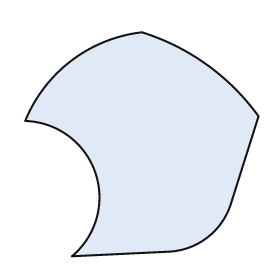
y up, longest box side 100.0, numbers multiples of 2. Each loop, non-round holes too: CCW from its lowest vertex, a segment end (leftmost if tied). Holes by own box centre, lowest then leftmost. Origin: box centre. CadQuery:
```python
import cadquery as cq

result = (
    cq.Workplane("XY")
    .moveTo(-30.0, -48.0)
    .lineTo(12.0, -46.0)
    .threePointArc((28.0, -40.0), (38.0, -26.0))
    .lineTo(50.0, 12.0)
    .threePointArc((28.0, 34.0), (0.0, 48.0))
    .threePointArc((-30.0, 36.0), (-50.0, 10.0))
    .threePointArc((-20.0, -12.0), (-30.0, -48.0))
    .close()
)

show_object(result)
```